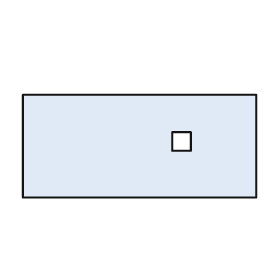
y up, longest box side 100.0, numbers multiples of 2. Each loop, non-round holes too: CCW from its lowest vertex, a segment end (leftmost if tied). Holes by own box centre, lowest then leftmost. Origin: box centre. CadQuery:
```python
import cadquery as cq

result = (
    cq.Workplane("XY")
    .moveTo(-50.0, -22.0)
    .lineTo(50.0, -22.0)
    .lineTo(50.0, 22.0)
    .lineTo(-50.0, 22.0)
    .close()
    .moveTo(14.0, -2.0)
    .lineTo(22.0, -2.0)
    .lineTo(22.0, 6.0)
    .lineTo(14.0, 6.0)
    .close()
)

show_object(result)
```